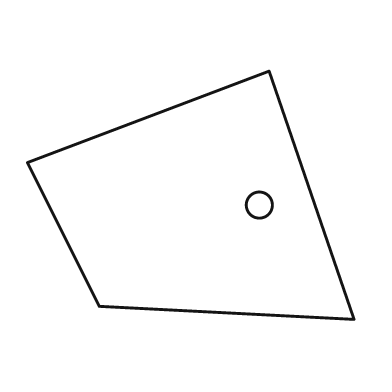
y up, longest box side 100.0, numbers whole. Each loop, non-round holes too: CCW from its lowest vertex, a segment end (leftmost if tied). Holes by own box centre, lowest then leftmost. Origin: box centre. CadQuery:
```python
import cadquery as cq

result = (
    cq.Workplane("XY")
    .moveTo(50.0, -38.0)
    .lineTo(24.0, 38.0)
    .lineTo(-50.0, 10.0)
    .lineTo(-28.0, -34.0)
    .close()
    .moveTo(21.0, -3.0)
    .circle(4.0)
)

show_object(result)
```